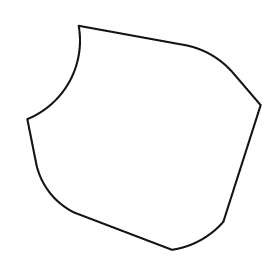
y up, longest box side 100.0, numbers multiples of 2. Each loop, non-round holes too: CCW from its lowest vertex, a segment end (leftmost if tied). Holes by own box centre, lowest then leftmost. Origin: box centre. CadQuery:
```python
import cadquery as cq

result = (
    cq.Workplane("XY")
    .moveTo(12.0, -48.0)
    .threePointArc((24.0, -44.0), (34.0, -36.0))
    .lineTo(50.0, 14.0)
    .lineTo(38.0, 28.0)
    .threePointArc((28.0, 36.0), (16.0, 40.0))
    .lineTo(-28.0, 48.0)
    .threePointArc((-32.0, 24.0), (-50.0, 8.0))
    .lineTo(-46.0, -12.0)
    .threePointArc((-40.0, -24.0), (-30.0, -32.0))
    .close()
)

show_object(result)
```